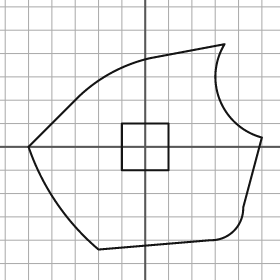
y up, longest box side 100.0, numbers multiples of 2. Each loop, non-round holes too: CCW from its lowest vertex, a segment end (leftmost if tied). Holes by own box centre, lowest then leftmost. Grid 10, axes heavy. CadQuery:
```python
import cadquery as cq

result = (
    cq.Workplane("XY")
    .moveTo(-20.0, -44.0)
    .lineTo(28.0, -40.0)
    .threePointArc((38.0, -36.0), (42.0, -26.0))
    .lineTo(50.0, 4.0)
    .threePointArc((32.0, 20.0), (34.0, 44.0))
    .lineTo(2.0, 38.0)
    .threePointArc((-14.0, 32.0), (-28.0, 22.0))
    .lineTo(-50.0, 0.0)
    .threePointArc((-38.0, -24.0), (-20.0, -44.0))
    .close()
    .moveTo(-10.0, -10.0)
    .lineTo(10.0, -10.0)
    .lineTo(10.0, 10.0)
    .lineTo(-10.0, 10.0)
    .close()
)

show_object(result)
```